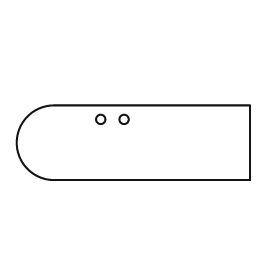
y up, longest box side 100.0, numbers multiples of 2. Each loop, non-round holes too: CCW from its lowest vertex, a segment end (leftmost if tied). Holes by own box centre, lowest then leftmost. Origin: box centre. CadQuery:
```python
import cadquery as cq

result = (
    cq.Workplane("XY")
    .moveTo(-34.0, -16.0)
    .lineTo(50.0, -16.0)
    .lineTo(50.0, 16.0)
    .lineTo(-34.0, 16.0)
    .threePointArc((-50.0, 0.0), (-34.0, -16.0))
    .close()
    .moveTo(-14.0, 10.0)
    .circle(2.0)
    .moveTo(-4.0, 10.0)
    .circle(2.0)
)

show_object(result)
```